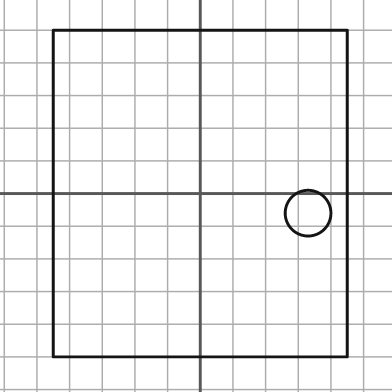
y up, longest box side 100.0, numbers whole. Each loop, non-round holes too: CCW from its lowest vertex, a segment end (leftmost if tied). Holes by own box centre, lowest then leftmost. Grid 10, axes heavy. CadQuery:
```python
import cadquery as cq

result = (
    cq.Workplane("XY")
    .moveTo(-45.0, -50.0)
    .lineTo(45.0, -50.0)
    .lineTo(45.0, 50.0)
    .lineTo(-45.0, 50.0)
    .close()
    .moveTo(33.0, -6.0)
    .circle(7.0)
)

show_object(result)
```